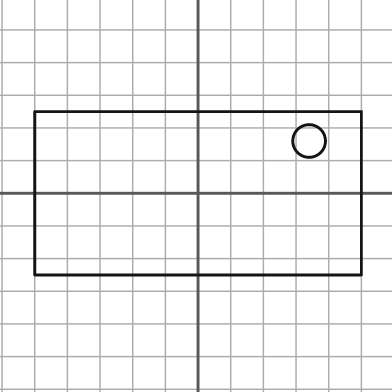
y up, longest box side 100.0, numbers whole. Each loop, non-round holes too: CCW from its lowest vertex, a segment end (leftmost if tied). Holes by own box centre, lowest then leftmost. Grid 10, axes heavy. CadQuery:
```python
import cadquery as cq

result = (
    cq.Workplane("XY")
    .moveTo(-50.0, -25.0)
    .lineTo(50.0, -25.0)
    .lineTo(50.0, 25.0)
    .lineTo(-50.0, 25.0)
    .close()
    .moveTo(34.0, 16.0)
    .circle(5.0)
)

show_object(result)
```